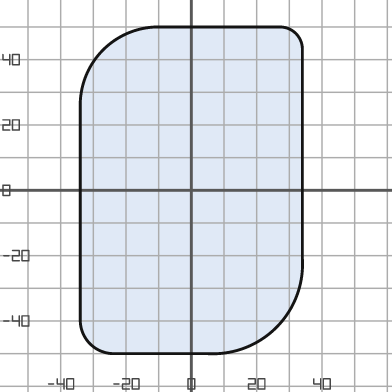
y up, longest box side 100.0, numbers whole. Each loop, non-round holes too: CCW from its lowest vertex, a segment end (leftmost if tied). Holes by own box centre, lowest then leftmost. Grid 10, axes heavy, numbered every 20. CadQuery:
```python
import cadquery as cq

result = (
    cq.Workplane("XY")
    .moveTo(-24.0, -50.0)
    .lineTo(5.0, -50.0)
    .threePointArc((26.0, -42.0), (34.0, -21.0))
    .lineTo(34.0, 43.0)
    .threePointArc((32.0, 48.0), (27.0, 50.0))
    .lineTo(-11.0, 50.0)
    .threePointArc((-27.0, 43.0), (-34.0, 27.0))
    .lineTo(-34.0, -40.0)
    .threePointArc((-31.0, -47.0), (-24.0, -50.0))
    .close()
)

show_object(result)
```